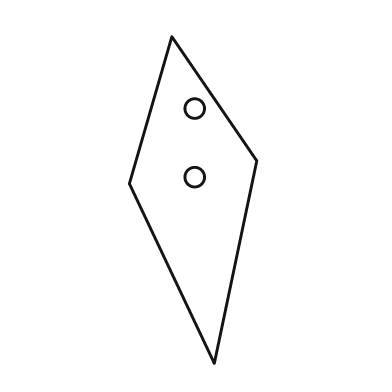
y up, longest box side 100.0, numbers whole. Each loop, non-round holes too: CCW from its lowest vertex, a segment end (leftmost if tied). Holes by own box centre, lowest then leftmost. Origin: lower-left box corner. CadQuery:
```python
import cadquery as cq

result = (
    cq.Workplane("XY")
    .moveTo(26.0, 0.0)
    .lineTo(39.0, 62.0)
    .lineTo(13.0, 100.0)
    .lineTo(0.0, 55.0)
    .close()
    .moveTo(20.0, 57.0)
    .circle(3.0)
    .moveTo(20.0, 78.0)
    .circle(3.0)
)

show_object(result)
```